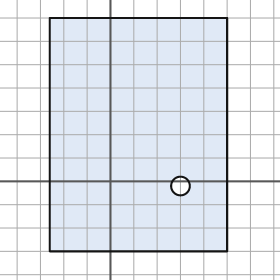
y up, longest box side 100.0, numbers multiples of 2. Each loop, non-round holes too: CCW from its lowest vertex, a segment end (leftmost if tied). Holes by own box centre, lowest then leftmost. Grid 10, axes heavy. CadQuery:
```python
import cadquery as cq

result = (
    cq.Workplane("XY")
    .moveTo(-26.0, -30.0)
    .lineTo(50.0, -30.0)
    .lineTo(50.0, 70.0)
    .lineTo(-26.0, 70.0)
    .close()
    .moveTo(30.0, -2.0)
    .circle(4.0)
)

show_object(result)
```